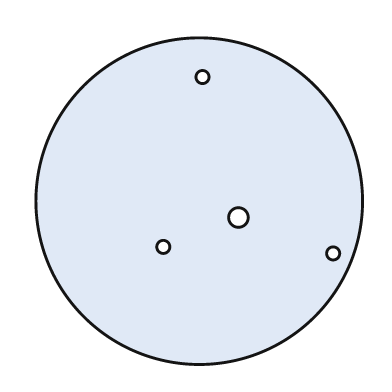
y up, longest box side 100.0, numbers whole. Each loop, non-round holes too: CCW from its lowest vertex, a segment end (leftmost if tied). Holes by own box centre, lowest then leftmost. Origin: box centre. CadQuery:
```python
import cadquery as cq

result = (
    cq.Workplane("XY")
    .moveTo(0.0, 0.0)
    .circle(50.0)
    .moveTo(41.0, -16.0)
    .circle(2.0)
    .moveTo(-11.0, -14.0)
    .circle(2.0)
    .moveTo(12.0, -5.0)
    .circle(3.0)
    .moveTo(1.0, 38.0)
    .circle(2.0)
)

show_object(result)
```